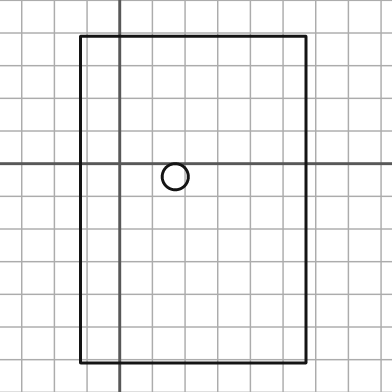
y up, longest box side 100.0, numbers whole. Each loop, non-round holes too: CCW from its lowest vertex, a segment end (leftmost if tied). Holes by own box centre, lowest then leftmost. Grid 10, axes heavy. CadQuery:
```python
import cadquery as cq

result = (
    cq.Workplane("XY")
    .moveTo(-12.0, -61.0)
    .lineTo(57.0, -61.0)
    .lineTo(57.0, 39.0)
    .lineTo(-12.0, 39.0)
    .close()
    .moveTo(17.0, -4.0)
    .circle(4.0)
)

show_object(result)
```